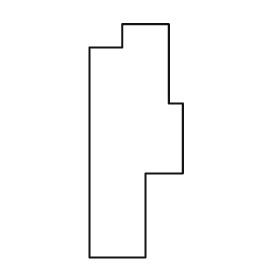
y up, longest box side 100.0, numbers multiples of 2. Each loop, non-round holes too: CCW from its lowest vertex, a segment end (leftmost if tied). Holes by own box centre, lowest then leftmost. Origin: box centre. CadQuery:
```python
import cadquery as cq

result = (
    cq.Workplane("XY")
    .moveTo(-20.0, -50.0)
    .lineTo(4.0, -50.0)
    .lineTo(4.0, -14.0)
    .lineTo(20.0, -14.0)
    .lineTo(20.0, 16.0)
    .lineTo(14.0, 16.0)
    .lineTo(14.0, 50.0)
    .lineTo(-6.0, 50.0)
    .lineTo(-6.0, 40.0)
    .lineTo(-20.0, 40.0)
    .close()
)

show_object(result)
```